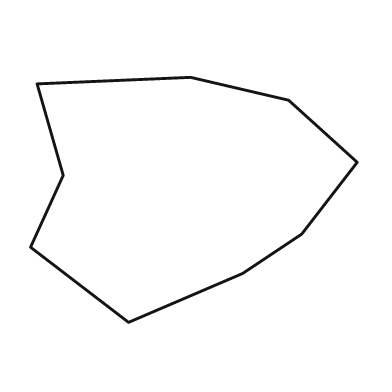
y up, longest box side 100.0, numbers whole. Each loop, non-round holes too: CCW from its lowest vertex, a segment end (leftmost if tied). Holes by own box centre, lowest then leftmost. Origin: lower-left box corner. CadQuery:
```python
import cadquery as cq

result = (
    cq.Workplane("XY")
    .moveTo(30.0, 0.0)
    .lineTo(65.0, 15.0)
    .lineTo(83.0, 27.0)
    .lineTo(100.0, 49.0)
    .lineTo(79.0, 68.0)
    .lineTo(49.0, 75.0)
    .lineTo(2.0, 73.0)
    .lineTo(10.0, 45.0)
    .lineTo(0.0, 23.0)
    .close()
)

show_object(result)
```